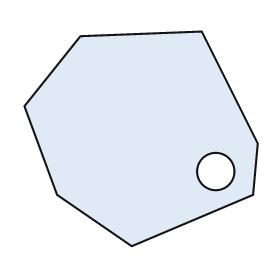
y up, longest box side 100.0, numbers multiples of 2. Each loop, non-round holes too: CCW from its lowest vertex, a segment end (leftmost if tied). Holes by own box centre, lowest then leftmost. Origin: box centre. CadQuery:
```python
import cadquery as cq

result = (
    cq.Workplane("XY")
    .moveTo(-4.0, -46.0)
    .lineTo(48.0, -24.0)
    .lineTo(50.0, -2.0)
    .lineTo(26.0, 46.0)
    .lineTo(-26.0, 44.0)
    .lineTo(-50.0, 14.0)
    .lineTo(-36.0, -24.0)
    .close()
    .moveTo(32.0, -14.0)
    .circle(8.0)
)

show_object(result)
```